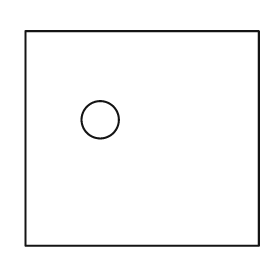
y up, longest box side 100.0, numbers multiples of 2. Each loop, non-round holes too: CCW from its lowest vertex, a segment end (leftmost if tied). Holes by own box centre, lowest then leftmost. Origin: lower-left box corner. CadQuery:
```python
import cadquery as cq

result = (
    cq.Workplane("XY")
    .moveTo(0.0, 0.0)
    .lineTo(100.0, 0.0)
    .lineTo(100.0, 92.0)
    .lineTo(0.0, 92.0)
    .close()
    .moveTo(32.0, 54.0)
    .circle(8.0)
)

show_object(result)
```